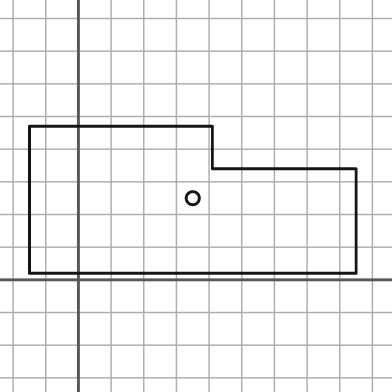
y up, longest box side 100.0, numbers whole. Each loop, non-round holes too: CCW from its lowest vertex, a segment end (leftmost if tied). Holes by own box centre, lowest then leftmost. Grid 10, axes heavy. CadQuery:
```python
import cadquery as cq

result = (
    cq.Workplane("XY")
    .moveTo(-15.0, 2.0)
    .lineTo(85.0, 2.0)
    .lineTo(85.0, 34.0)
    .lineTo(41.0, 34.0)
    .lineTo(41.0, 47.0)
    .lineTo(-15.0, 47.0)
    .close()
    .moveTo(35.0, 25.0)
    .circle(2.0)
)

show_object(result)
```